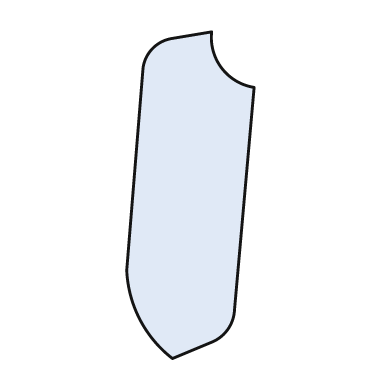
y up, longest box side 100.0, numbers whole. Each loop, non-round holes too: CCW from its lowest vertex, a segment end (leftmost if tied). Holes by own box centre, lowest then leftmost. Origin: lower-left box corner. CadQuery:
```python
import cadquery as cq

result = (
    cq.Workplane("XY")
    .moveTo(14.0, 0.0)
    .lineTo(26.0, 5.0)
    .threePointArc((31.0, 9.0), (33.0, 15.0))
    .lineTo(39.0, 83.0)
    .threePointArc((29.0, 89.0), (26.0, 100.0))
    .lineTo(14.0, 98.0)
    .threePointArc((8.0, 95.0), (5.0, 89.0))
    .lineTo(0.0, 27.0)
    .threePointArc((4.0, 12.0), (14.0, 0.0))
    .close()
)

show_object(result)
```